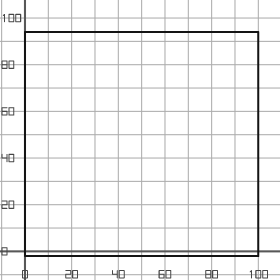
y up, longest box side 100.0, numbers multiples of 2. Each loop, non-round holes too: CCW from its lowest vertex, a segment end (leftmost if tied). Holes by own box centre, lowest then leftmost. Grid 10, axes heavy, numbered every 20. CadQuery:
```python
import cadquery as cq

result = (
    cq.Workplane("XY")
    .moveTo(0.0, -2.0)
    .lineTo(100.0, -2.0)
    .lineTo(100.0, 94.0)
    .lineTo(0.0, 94.0)
    .close()
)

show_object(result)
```